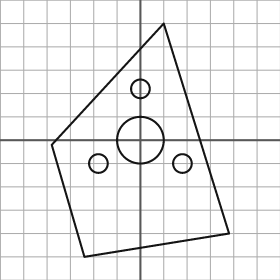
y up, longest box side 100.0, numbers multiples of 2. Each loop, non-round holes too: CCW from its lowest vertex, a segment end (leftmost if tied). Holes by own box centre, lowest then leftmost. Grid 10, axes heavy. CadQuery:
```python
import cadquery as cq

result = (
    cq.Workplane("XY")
    .moveTo(-24.0, -50.0)
    .lineTo(38.0, -40.0)
    .lineTo(10.0, 50.0)
    .lineTo(-38.0, -2.0)
    .close()
    .moveTo(-18.0, -10.0)
    .circle(4.0)
    .moveTo(18.0, -10.0)
    .circle(4.0)
    .moveTo(0.0, 0.0)
    .circle(10.0)
    .moveTo(0.0, 22.0)
    .circle(4.0)
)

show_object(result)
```